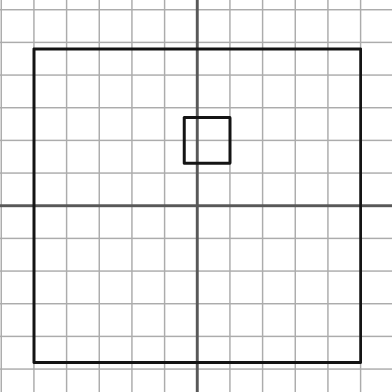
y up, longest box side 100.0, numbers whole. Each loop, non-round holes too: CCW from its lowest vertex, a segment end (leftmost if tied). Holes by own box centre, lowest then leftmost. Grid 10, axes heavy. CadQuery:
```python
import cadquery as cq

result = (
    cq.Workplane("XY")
    .moveTo(-50.0, -48.0)
    .lineTo(50.0, -48.0)
    .lineTo(50.0, 48.0)
    .lineTo(-50.0, 48.0)
    .close()
    .moveTo(-4.0, 13.0)
    .lineTo(10.0, 13.0)
    .lineTo(10.0, 27.0)
    .lineTo(-4.0, 27.0)
    .close()
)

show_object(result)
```